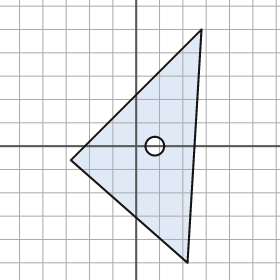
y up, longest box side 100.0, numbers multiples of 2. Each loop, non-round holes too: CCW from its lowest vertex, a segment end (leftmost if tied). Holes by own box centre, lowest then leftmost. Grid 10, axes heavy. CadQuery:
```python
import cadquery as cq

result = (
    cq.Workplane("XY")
    .moveTo(22.0, -50.0)
    .lineTo(28.0, 50.0)
    .lineTo(-28.0, -6.0)
    .close()
    .moveTo(8.0, 0.0)
    .circle(4.0)
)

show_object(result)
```